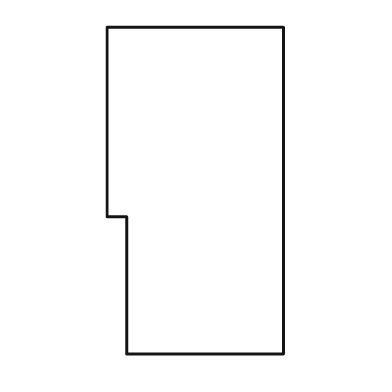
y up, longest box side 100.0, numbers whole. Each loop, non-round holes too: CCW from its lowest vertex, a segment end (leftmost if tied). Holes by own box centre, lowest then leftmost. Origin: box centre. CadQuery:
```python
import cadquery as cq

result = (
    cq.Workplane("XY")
    .moveTo(-21.0, -50.0)
    .lineTo(27.0, -50.0)
    .lineTo(27.0, 50.0)
    .lineTo(-27.0, 50.0)
    .lineTo(-27.0, -8.0)
    .lineTo(-21.0, -8.0)
    .close()
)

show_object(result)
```